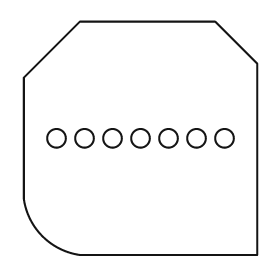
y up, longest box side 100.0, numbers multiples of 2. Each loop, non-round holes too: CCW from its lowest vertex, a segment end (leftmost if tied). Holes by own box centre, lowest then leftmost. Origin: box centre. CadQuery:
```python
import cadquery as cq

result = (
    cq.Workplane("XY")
    .moveTo(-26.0, -50.0)
    .lineTo(50.0, -50.0)
    .lineTo(50.0, 32.0)
    .lineTo(32.0, 50.0)
    .lineTo(-26.0, 50.0)
    .lineTo(-50.0, 26.0)
    .lineTo(-50.0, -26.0)
    .threePointArc((-42.0, -42.0), (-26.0, -50.0))
    .close()
    .moveTo(-36.0, 0.0)
    .circle(4.0)
    .moveTo(-24.0, 0.0)
    .circle(4.0)
    .moveTo(-12.0, 0.0)
    .circle(4.0)
    .moveTo(0.0, 0.0)
    .circle(4.0)
    .moveTo(12.0, 0.0)
    .circle(4.0)
    .moveTo(24.0, 0.0)
    .circle(4.0)
    .moveTo(36.0, 0.0)
    .circle(4.0)
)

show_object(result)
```